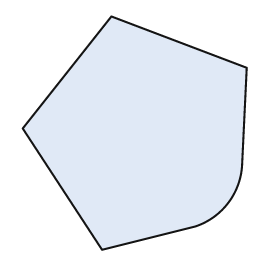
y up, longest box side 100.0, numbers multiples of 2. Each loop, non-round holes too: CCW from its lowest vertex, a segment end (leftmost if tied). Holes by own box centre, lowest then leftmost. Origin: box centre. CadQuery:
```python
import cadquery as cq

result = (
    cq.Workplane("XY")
    .moveTo(-14.0, -50.0)
    .lineTo(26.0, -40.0)
    .threePointArc((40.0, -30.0), (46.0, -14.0))
    .lineTo(48.0, 28.0)
    .lineTo(-10.0, 50.0)
    .lineTo(-48.0, 2.0)
    .close()
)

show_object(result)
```